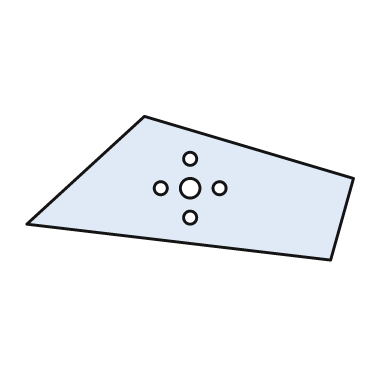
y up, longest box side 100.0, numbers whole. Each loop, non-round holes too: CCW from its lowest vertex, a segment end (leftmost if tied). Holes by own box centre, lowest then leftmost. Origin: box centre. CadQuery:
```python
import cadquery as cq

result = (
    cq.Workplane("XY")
    .moveTo(43.0, -22.0)
    .lineTo(50.0, 3.0)
    .lineTo(-14.0, 22.0)
    .lineTo(-50.0, -11.0)
    .close()
    .moveTo(0.0, -9.0)
    .circle(2.0)
    .moveTo(-9.0, 0.0)
    .circle(2.0)
    .moveTo(0.0, 0.0)
    .circle(3.0)
    .moveTo(9.0, 0.0)
    .circle(2.0)
    .moveTo(0.0, 9.0)
    .circle(2.0)
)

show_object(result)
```